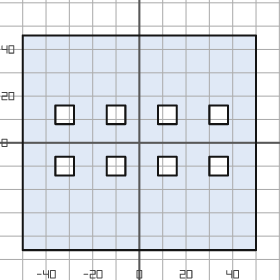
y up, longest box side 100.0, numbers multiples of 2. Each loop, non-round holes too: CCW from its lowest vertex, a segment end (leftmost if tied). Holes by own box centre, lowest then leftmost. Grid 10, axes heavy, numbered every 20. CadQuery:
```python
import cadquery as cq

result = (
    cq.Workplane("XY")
    .moveTo(-50.0, -46.0)
    .lineTo(50.0, -46.0)
    .lineTo(50.0, 46.0)
    .lineTo(-50.0, 46.0)
    .close()
    .moveTo(-36.0, -14.0)
    .lineTo(-28.0, -14.0)
    .lineTo(-28.0, -6.0)
    .lineTo(-36.0, -6.0)
    .close()
    .moveTo(-14.0, -14.0)
    .lineTo(-6.0, -14.0)
    .lineTo(-6.0, -6.0)
    .lineTo(-14.0, -6.0)
    .close()
    .moveTo(8.0, -14.0)
    .lineTo(16.0, -14.0)
    .lineTo(16.0, -6.0)
    .lineTo(8.0, -6.0)
    .close()
    .moveTo(30.0, -14.0)
    .lineTo(38.0, -14.0)
    .lineTo(38.0, -6.0)
    .lineTo(30.0, -6.0)
    .close()
    .moveTo(-36.0, 8.0)
    .lineTo(-28.0, 8.0)
    .lineTo(-28.0, 16.0)
    .lineTo(-36.0, 16.0)
    .close()
    .moveTo(-14.0, 8.0)
    .lineTo(-6.0, 8.0)
    .lineTo(-6.0, 16.0)
    .lineTo(-14.0, 16.0)
    .close()
    .moveTo(8.0, 8.0)
    .lineTo(16.0, 8.0)
    .lineTo(16.0, 16.0)
    .lineTo(8.0, 16.0)
    .close()
    .moveTo(30.0, 8.0)
    .lineTo(38.0, 8.0)
    .lineTo(38.0, 16.0)
    .lineTo(30.0, 16.0)
    .close()
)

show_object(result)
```